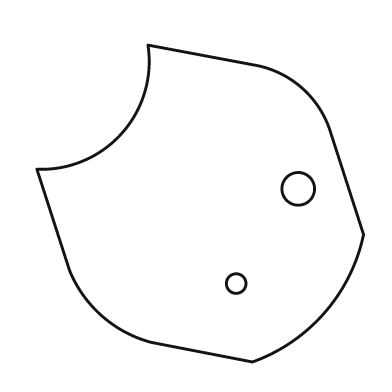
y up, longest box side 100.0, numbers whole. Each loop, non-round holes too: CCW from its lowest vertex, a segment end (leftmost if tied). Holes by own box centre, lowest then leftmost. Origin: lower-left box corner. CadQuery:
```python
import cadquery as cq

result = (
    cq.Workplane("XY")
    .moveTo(66.0, 0.0)
    .threePointArc((88.0, 15.0), (100.0, 39.0))
    .lineTo(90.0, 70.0)
    .threePointArc((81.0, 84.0), (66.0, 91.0))
    .lineTo(34.0, 97.0)
    .threePointArc((26.0, 70.0), (0.0, 59.0))
    .lineTo(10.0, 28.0)
    .threePointArc((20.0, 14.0), (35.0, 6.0))
    .close()
    .moveTo(61.0, 24.0)
    .circle(3.0)
    .moveTo(80.0, 53.0)
    .circle(5.0)
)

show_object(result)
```